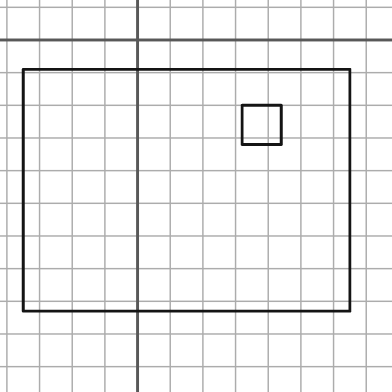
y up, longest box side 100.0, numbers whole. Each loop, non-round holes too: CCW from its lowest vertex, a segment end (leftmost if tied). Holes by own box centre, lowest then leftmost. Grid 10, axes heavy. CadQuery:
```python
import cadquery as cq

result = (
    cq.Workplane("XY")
    .moveTo(-35.0, -83.0)
    .lineTo(65.0, -83.0)
    .lineTo(65.0, -9.0)
    .lineTo(-35.0, -9.0)
    .close()
    .moveTo(32.0, -32.0)
    .lineTo(44.0, -32.0)
    .lineTo(44.0, -20.0)
    .lineTo(32.0, -20.0)
    .close()
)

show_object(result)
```